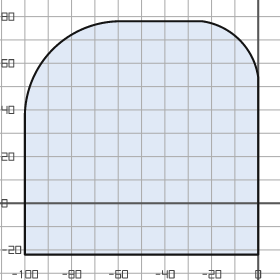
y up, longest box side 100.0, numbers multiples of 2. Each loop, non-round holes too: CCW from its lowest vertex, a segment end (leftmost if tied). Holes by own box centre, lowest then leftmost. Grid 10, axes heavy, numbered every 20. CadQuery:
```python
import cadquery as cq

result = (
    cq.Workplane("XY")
    .moveTo(-100.0, -22.0)
    .lineTo(0.0, -22.0)
    .lineTo(0.0, 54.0)
    .threePointArc((-8.0, 70.0), (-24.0, 78.0))
    .lineTo(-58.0, 78.0)
    .threePointArc((-88.0, 66.0), (-100.0, 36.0))
    .close()
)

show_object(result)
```